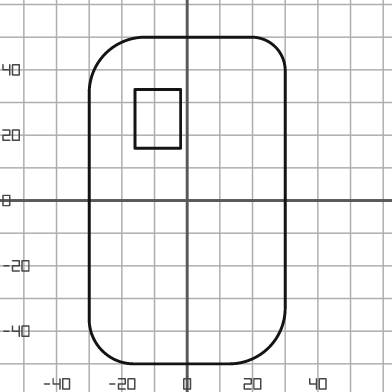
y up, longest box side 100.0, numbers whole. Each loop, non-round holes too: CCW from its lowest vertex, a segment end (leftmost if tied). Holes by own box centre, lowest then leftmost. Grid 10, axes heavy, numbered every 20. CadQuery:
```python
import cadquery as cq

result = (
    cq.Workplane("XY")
    .moveTo(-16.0, -50.0)
    .lineTo(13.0, -50.0)
    .threePointArc((25.0, -45.0), (30.0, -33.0))
    .lineTo(30.0, 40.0)
    .threePointArc((27.0, 47.0), (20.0, 50.0))
    .lineTo(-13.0, 50.0)
    .threePointArc((-25.0, 45.0), (-30.0, 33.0))
    .lineTo(-30.0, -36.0)
    .threePointArc((-26.0, -46.0), (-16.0, -50.0))
    .close()
    .moveTo(-16.0, 16.0)
    .lineTo(-2.0, 16.0)
    .lineTo(-2.0, 34.0)
    .lineTo(-16.0, 34.0)
    .close()
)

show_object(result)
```